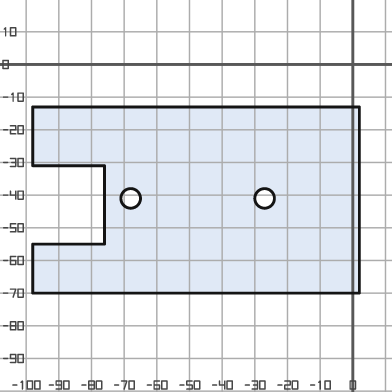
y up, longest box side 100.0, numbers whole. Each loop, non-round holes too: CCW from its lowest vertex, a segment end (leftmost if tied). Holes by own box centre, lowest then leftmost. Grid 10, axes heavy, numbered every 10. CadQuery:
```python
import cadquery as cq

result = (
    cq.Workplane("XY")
    .moveTo(-98.0, -70.0)
    .lineTo(2.0, -70.0)
    .lineTo(2.0, -13.0)
    .lineTo(-98.0, -13.0)
    .lineTo(-98.0, -31.0)
    .lineTo(-76.0, -31.0)
    .lineTo(-76.0, -55.0)
    .lineTo(-98.0, -55.0)
    .close()
    .moveTo(-68.0, -41.0)
    .circle(3.0)
    .moveTo(-27.0, -41.0)
    .circle(3.0)
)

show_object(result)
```